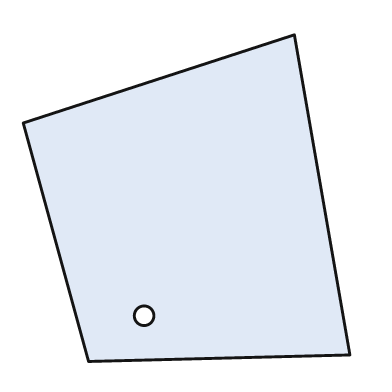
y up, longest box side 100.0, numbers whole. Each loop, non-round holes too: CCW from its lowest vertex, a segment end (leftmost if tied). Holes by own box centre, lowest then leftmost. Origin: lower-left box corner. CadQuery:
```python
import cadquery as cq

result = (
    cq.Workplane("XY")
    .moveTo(20.0, 0.0)
    .lineTo(100.0, 2.0)
    .lineTo(83.0, 100.0)
    .lineTo(0.0, 73.0)
    .close()
    .moveTo(37.0, 14.0)
    .circle(3.0)
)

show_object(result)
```